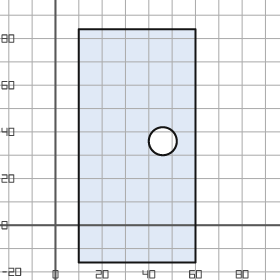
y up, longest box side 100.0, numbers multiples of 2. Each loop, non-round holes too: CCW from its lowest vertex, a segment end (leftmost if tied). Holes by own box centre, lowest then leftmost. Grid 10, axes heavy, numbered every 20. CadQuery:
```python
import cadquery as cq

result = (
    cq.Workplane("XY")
    .moveTo(10.0, -16.0)
    .lineTo(60.0, -16.0)
    .lineTo(60.0, 84.0)
    .lineTo(10.0, 84.0)
    .close()
    .moveTo(46.0, 36.0)
    .circle(6.0)
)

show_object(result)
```